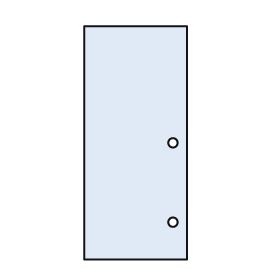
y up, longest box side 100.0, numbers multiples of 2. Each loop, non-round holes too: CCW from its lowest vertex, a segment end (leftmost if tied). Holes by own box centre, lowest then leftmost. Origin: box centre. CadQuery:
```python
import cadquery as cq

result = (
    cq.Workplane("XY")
    .moveTo(-22.0, -50.0)
    .lineTo(22.0, -50.0)
    .lineTo(22.0, 50.0)
    .lineTo(-22.0, 50.0)
    .close()
    .moveTo(16.0, -34.0)
    .circle(2.0)
    .moveTo(16.0, 0.0)
    .circle(2.0)
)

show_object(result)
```